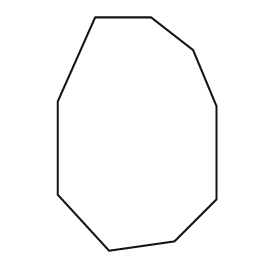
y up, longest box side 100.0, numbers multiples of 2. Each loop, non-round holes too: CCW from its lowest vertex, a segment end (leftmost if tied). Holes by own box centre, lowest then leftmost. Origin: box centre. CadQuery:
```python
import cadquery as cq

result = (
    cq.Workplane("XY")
    .moveTo(-12.0, -50.0)
    .lineTo(16.0, -46.0)
    .lineTo(34.0, -28.0)
    .lineTo(34.0, 12.0)
    .lineTo(24.0, 36.0)
    .lineTo(6.0, 50.0)
    .lineTo(-18.0, 50.0)
    .lineTo(-34.0, 14.0)
    .lineTo(-34.0, -26.0)
    .close()
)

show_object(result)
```